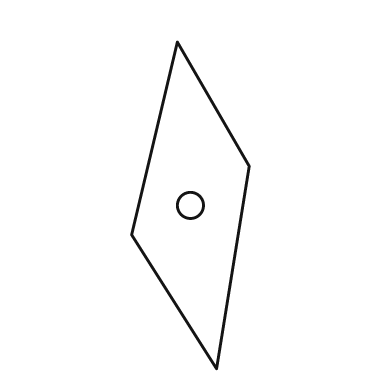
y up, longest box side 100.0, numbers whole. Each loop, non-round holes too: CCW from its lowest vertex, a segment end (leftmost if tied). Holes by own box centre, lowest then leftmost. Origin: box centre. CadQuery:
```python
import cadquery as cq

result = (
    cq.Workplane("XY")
    .moveTo(8.0, -50.0)
    .lineTo(18.0, 12.0)
    .lineTo(-4.0, 50.0)
    .lineTo(-18.0, -9.0)
    .close()
    .moveTo(0.0, 0.0)
    .circle(4.0)
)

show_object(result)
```